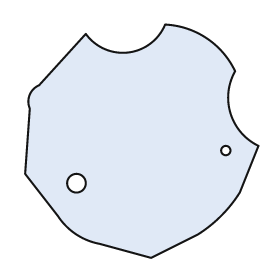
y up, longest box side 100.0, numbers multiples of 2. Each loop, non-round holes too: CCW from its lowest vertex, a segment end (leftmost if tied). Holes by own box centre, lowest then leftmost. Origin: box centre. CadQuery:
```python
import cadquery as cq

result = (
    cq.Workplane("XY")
    .moveTo(4.0, -50.0)
    .lineTo(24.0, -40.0)
    .threePointArc((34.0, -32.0), (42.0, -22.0))
    .lineTo(50.0, -2.0)
    .threePointArc((38.0, 12.0), (40.0, 30.0))
    .threePointArc((28.0, 44.0), (10.0, 50.0))
    .threePointArc((-6.0, 38.0), (-24.0, 46.0))
    .lineTo(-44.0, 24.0)
    .threePointArc((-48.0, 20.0), (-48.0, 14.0))
    .lineTo(-50.0, -14.0)
    .lineTo(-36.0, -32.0)
    .threePointArc((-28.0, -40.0), (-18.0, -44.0))
    .close()
    .moveTo(-28.0, -18.0)
    .circle(4.0)
    .moveTo(36.0, -4.0)
    .circle(2.0)
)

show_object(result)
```